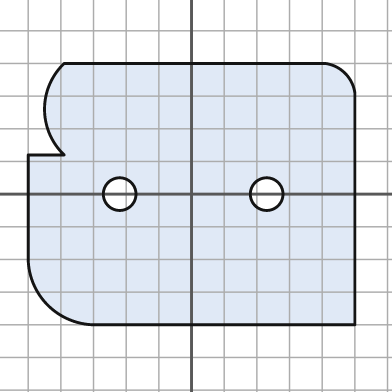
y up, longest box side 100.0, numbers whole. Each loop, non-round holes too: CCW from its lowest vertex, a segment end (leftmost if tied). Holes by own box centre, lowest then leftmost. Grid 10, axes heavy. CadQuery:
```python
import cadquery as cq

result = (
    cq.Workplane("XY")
    .moveTo(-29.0, -40.0)
    .lineTo(50.0, -40.0)
    .lineTo(50.0, 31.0)
    .threePointArc((47.0, 37.0), (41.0, 40.0))
    .lineTo(-39.0, 40.0)
    .threePointArc((-45.0, 26.0), (-39.0, 12.0))
    .lineTo(-50.0, 12.0)
    .lineTo(-50.0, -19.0)
    .threePointArc((-44.0, -34.0), (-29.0, -40.0))
    .close()
    .moveTo(-22.0, 0.0)
    .circle(5.0)
    .moveTo(23.0, 0.0)
    .circle(5.0)
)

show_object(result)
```